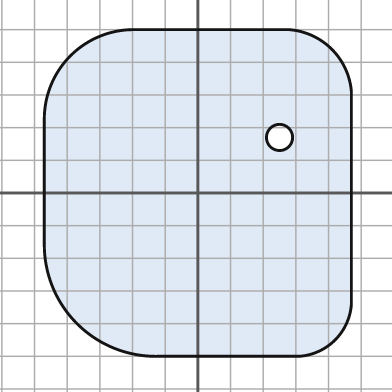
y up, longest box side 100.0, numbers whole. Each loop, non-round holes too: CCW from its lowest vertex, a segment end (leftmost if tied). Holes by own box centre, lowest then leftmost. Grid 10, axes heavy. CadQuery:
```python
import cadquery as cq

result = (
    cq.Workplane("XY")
    .moveTo(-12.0, -50.0)
    .lineTo(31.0, -50.0)
    .threePointArc((42.0, -45.0), (47.0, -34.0))
    .lineTo(47.0, 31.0)
    .threePointArc((41.0, 44.0), (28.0, 50.0))
    .lineTo(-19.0, 50.0)
    .threePointArc((-39.0, 42.0), (-47.0, 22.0))
    .lineTo(-47.0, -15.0)
    .threePointArc((-37.0, -40.0), (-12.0, -50.0))
    .close()
    .moveTo(25.0, 17.0)
    .circle(4.0)
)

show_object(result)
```